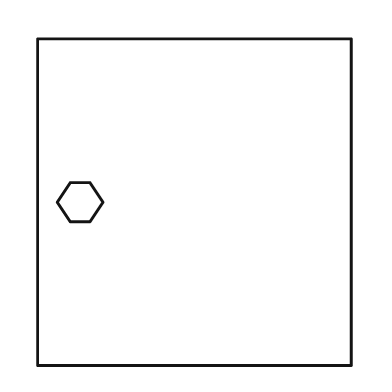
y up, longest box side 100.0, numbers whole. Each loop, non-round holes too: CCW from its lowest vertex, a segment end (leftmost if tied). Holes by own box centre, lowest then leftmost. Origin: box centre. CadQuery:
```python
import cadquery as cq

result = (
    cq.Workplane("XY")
    .moveTo(-48.0, -50.0)
    .lineTo(48.0, -50.0)
    .lineTo(48.0, 50.0)
    .lineTo(-48.0, 50.0)
    .close()
    .moveTo(-38.0, -6.0)
    .lineTo(-32.0, -6.0)
    .lineTo(-28.0, 0.0)
    .lineTo(-32.0, 6.0)
    .lineTo(-38.0, 6.0)
    .lineTo(-42.0, 0.0)
    .close()
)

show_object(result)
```